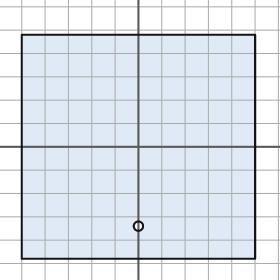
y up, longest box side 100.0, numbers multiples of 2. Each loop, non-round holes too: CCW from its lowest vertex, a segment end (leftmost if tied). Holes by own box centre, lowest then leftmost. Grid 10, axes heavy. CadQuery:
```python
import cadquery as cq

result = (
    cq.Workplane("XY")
    .moveTo(-50.0, -48.0)
    .lineTo(50.0, -48.0)
    .lineTo(50.0, 48.0)
    .lineTo(-50.0, 48.0)
    .close()
    .moveTo(0.0, -34.0)
    .circle(2.0)
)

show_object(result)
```